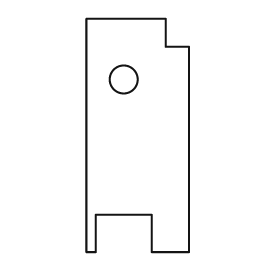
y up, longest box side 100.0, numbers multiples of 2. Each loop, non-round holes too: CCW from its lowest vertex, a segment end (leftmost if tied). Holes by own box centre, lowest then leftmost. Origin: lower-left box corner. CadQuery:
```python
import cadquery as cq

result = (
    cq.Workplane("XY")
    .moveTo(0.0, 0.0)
    .lineTo(4.0, 0.0)
    .lineTo(4.0, 16.0)
    .lineTo(28.0, 16.0)
    .lineTo(28.0, 0.0)
    .lineTo(44.0, 0.0)
    .lineTo(44.0, 88.0)
    .lineTo(34.0, 88.0)
    .lineTo(34.0, 100.0)
    .lineTo(0.0, 100.0)
    .close()
    .moveTo(16.0, 74.0)
    .circle(6.0)
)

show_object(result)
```